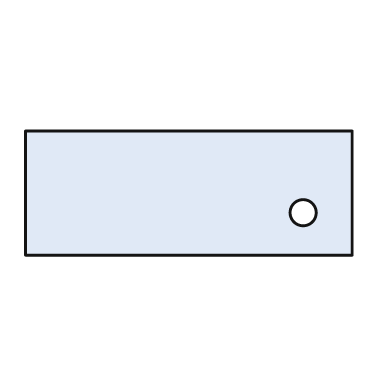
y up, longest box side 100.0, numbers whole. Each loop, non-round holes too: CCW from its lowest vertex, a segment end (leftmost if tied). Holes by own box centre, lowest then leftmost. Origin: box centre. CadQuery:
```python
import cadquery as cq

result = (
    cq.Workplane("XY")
    .moveTo(-50.0, -19.0)
    .lineTo(50.0, -19.0)
    .lineTo(50.0, 19.0)
    .lineTo(-50.0, 19.0)
    .close()
    .moveTo(35.0, -6.0)
    .circle(4.0)
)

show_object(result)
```